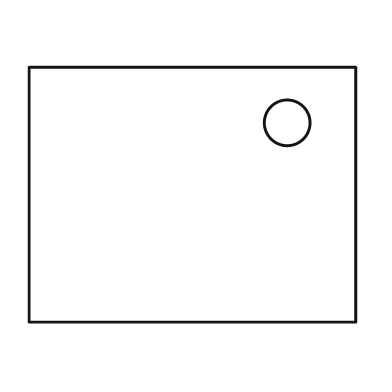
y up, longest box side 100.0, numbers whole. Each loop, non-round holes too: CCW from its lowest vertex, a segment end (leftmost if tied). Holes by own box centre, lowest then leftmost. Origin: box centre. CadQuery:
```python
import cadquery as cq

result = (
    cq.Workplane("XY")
    .moveTo(-50.0, -39.0)
    .lineTo(50.0, -39.0)
    .lineTo(50.0, 39.0)
    .lineTo(-50.0, 39.0)
    .close()
    .moveTo(29.0, 22.0)
    .circle(7.0)
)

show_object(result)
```